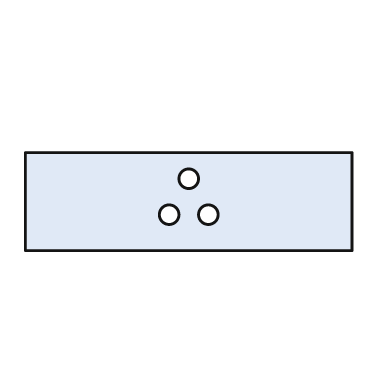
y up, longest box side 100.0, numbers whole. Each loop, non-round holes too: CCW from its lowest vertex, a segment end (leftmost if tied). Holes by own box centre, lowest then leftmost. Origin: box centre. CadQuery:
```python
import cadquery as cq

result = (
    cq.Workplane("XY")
    .moveTo(-50.0, -15.0)
    .lineTo(50.0, -15.0)
    .lineTo(50.0, 15.0)
    .lineTo(-50.0, 15.0)
    .close()
    .moveTo(-6.0, -4.0)
    .circle(3.0)
    .moveTo(6.0, -4.0)
    .circle(3.0)
    .moveTo(0.0, 7.0)
    .circle(3.0)
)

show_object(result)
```